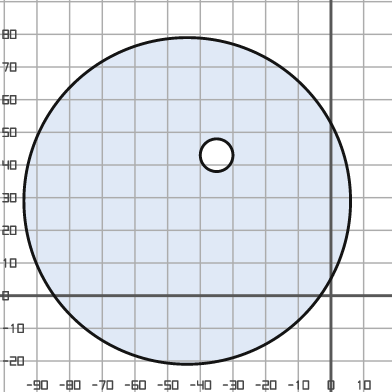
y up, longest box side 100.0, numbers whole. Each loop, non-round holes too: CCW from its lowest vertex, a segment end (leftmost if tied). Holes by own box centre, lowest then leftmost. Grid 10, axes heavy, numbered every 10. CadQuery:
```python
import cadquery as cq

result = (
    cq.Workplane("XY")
    .moveTo(-44.0, 29.0)
    .circle(50.0)
    .moveTo(-35.0, 43.0)
    .circle(5.0)
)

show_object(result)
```